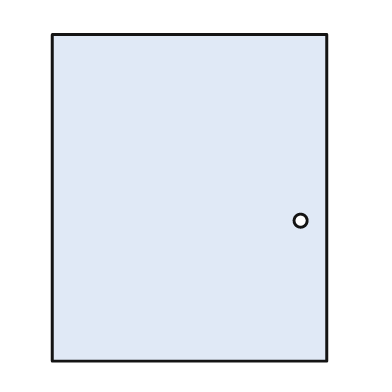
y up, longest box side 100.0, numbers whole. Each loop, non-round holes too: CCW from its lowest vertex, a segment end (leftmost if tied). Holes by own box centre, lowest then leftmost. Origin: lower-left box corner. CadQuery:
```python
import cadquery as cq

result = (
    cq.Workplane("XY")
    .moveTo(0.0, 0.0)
    .lineTo(84.0, 0.0)
    .lineTo(84.0, 100.0)
    .lineTo(0.0, 100.0)
    .close()
    .moveTo(76.0, 43.0)
    .circle(2.0)
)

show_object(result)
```